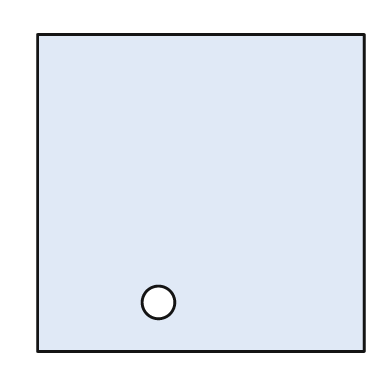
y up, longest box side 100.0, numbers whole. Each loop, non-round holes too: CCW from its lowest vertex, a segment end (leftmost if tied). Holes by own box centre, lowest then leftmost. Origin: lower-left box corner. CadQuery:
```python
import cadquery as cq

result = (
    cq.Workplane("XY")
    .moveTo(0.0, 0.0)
    .lineTo(100.0, 0.0)
    .lineTo(100.0, 97.0)
    .lineTo(0.0, 97.0)
    .close()
    .moveTo(37.0, 15.0)
    .circle(5.0)
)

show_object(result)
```